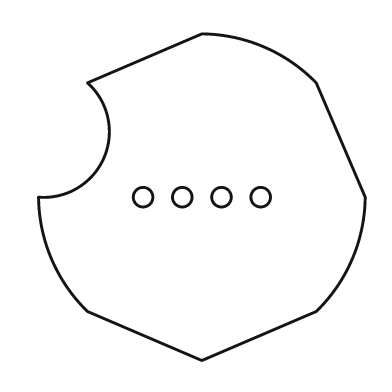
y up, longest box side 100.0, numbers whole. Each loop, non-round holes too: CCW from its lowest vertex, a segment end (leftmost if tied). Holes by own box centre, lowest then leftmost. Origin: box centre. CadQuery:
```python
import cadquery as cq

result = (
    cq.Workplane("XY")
    .moveTo(0.0, -50.0)
    .lineTo(35.0, -35.0)
    .threePointArc((46.0, -19.0), (50.0, 0.0))
    .lineTo(35.0, 35.0)
    .threePointArc((19.0, 46.0), (0.0, 50.0))
    .lineTo(-35.0, 35.0)
    .threePointArc((-30.0, 12.0), (-50.0, 0.0))
    .threePointArc((-46.0, -19.0), (-35.0, -35.0))
    .close()
    .moveTo(-18.0, 0.0)
    .circle(3.0)
    .moveTo(-6.0, 0.0)
    .circle(3.0)
    .moveTo(6.0, 0.0)
    .circle(3.0)
    .moveTo(18.0, 0.0)
    .circle(3.0)
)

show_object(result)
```